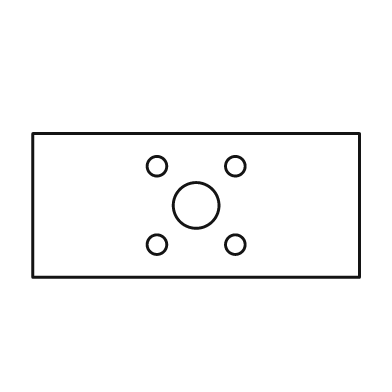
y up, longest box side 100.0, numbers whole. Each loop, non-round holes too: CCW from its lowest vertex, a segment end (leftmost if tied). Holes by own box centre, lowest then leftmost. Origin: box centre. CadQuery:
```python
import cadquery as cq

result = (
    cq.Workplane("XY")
    .moveTo(-50.0, -22.0)
    .lineTo(50.0, -22.0)
    .lineTo(50.0, 22.0)
    .lineTo(-50.0, 22.0)
    .close()
    .moveTo(-12.0, -12.0)
    .circle(3.0)
    .moveTo(12.0, -12.0)
    .circle(3.0)
    .moveTo(0.0, 0.0)
    .circle(7.0)
    .moveTo(-12.0, 12.0)
    .circle(3.0)
    .moveTo(12.0, 12.0)
    .circle(3.0)
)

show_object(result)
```